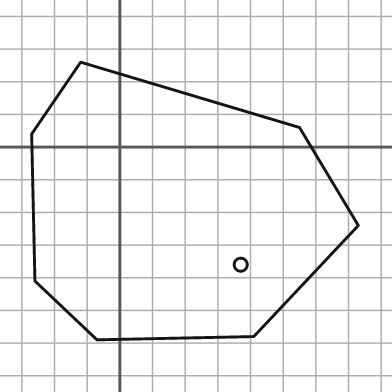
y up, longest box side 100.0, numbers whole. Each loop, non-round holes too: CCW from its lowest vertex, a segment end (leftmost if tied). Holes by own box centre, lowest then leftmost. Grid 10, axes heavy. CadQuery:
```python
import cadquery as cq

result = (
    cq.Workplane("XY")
    .moveTo(-7.0, -59.0)
    .lineTo(41.0, -58.0)
    .lineTo(73.0, -24.0)
    .lineTo(55.0, 6.0)
    .lineTo(-12.0, 26.0)
    .lineTo(-27.0, 4.0)
    .lineTo(-26.0, -41.0)
    .close()
    .moveTo(37.0, -36.0)
    .circle(2.0)
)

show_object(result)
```